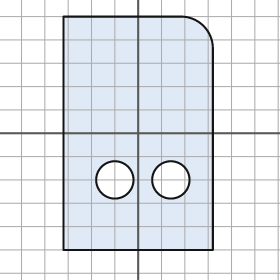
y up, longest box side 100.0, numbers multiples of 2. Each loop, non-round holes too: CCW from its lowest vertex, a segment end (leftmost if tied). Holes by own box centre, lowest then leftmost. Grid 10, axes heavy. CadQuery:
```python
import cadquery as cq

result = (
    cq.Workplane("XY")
    .moveTo(-32.0, -50.0)
    .lineTo(32.0, -50.0)
    .lineTo(32.0, 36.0)
    .threePointArc((28.0, 46.0), (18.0, 50.0))
    .lineTo(-32.0, 50.0)
    .close()
    .moveTo(-10.0, -20.0)
    .circle(8.0)
    .moveTo(14.0, -20.0)
    .circle(8.0)
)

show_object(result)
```